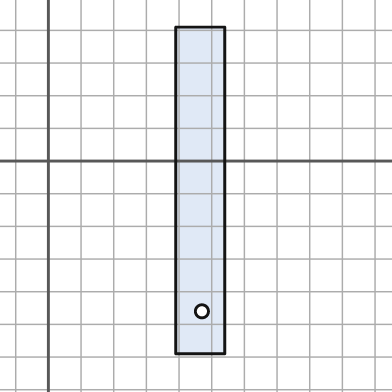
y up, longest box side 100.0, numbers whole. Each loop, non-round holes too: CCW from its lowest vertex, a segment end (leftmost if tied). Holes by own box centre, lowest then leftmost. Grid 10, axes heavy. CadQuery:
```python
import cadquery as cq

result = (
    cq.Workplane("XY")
    .moveTo(39.0, -59.0)
    .lineTo(54.0, -59.0)
    .lineTo(54.0, 41.0)
    .lineTo(39.0, 41.0)
    .close()
    .moveTo(47.0, -46.0)
    .circle(2.0)
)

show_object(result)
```